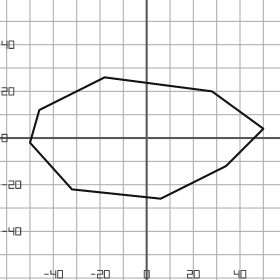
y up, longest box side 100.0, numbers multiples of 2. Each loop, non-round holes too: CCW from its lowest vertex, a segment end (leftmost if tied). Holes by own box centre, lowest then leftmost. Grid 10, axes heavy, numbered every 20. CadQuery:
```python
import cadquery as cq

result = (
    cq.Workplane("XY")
    .moveTo(6.0, -26.0)
    .lineTo(34.0, -12.0)
    .lineTo(50.0, 4.0)
    .lineTo(28.0, 20.0)
    .lineTo(-18.0, 26.0)
    .lineTo(-46.0, 12.0)
    .lineTo(-50.0, -2.0)
    .lineTo(-32.0, -22.0)
    .close()
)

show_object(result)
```